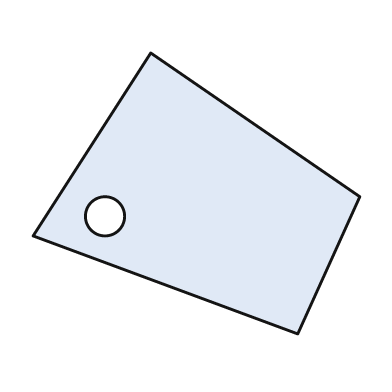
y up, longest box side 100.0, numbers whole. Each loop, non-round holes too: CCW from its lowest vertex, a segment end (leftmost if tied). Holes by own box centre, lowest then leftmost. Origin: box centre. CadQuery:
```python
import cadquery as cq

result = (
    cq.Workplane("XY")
    .moveTo(31.0, -43.0)
    .lineTo(50.0, -1.0)
    .lineTo(-14.0, 43.0)
    .lineTo(-50.0, -13.0)
    .close()
    .moveTo(-28.0, -7.0)
    .circle(6.0)
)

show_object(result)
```